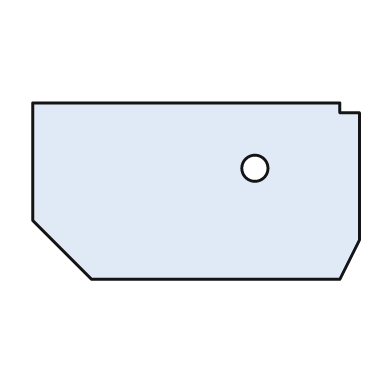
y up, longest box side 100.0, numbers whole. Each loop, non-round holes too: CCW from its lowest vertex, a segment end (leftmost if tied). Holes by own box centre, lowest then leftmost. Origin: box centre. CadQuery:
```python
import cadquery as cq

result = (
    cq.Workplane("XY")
    .moveTo(-32.0, -27.0)
    .lineTo(44.0, -27.0)
    .lineTo(50.0, -15.0)
    .lineTo(50.0, 24.0)
    .lineTo(44.0, 24.0)
    .lineTo(44.0, 27.0)
    .lineTo(-50.0, 27.0)
    .lineTo(-50.0, -9.0)
    .close()
    .moveTo(18.0, 7.0)
    .circle(4.0)
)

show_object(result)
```